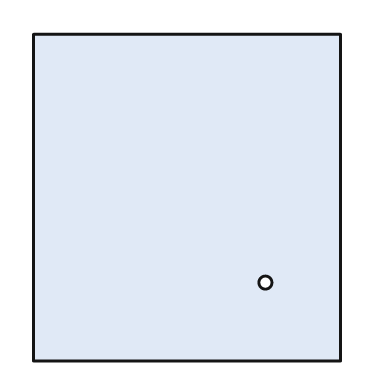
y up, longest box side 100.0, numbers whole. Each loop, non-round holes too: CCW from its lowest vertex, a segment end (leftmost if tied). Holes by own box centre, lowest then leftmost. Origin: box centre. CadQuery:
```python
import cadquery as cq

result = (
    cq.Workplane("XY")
    .moveTo(-47.0, -50.0)
    .lineTo(47.0, -50.0)
    .lineTo(47.0, 50.0)
    .lineTo(-47.0, 50.0)
    .close()
    .moveTo(24.0, -26.0)
    .circle(2.0)
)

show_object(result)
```